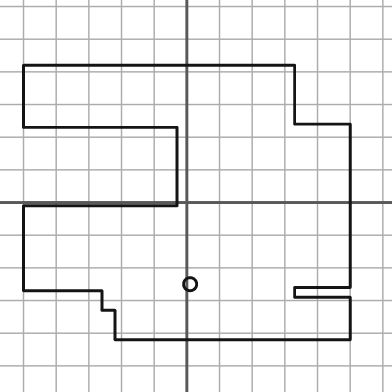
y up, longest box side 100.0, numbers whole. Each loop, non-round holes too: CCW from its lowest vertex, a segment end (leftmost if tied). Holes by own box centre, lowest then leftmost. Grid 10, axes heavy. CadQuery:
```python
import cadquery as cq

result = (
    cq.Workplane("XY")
    .moveTo(-22.0, -42.0)
    .lineTo(50.0, -42.0)
    .lineTo(50.0, -29.0)
    .lineTo(33.0, -29.0)
    .lineTo(33.0, -26.0)
    .lineTo(50.0, -26.0)
    .lineTo(50.0, 24.0)
    .lineTo(33.0, 24.0)
    .lineTo(33.0, 42.0)
    .lineTo(-50.0, 42.0)
    .lineTo(-50.0, 23.0)
    .lineTo(-3.0, 23.0)
    .lineTo(-3.0, -1.0)
    .lineTo(-50.0, -1.0)
    .lineTo(-50.0, -27.0)
    .lineTo(-26.0, -27.0)
    .lineTo(-26.0, -33.0)
    .lineTo(-22.0, -33.0)
    .close()
    .moveTo(1.0, -25.0)
    .circle(2.0)
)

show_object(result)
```